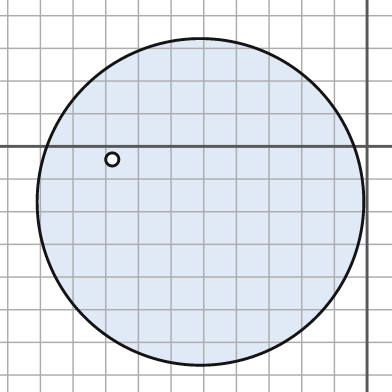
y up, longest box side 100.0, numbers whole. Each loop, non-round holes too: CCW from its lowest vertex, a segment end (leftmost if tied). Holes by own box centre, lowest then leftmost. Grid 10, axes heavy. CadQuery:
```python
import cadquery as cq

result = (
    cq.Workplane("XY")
    .moveTo(-51.0, -17.0)
    .circle(50.0)
    .moveTo(-78.0, -4.0)
    .circle(2.0)
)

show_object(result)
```